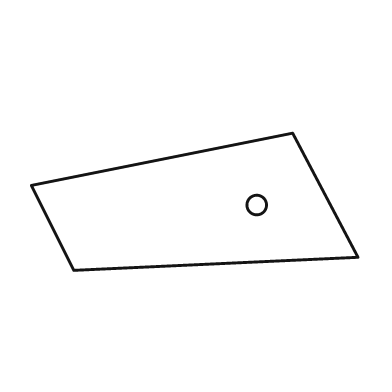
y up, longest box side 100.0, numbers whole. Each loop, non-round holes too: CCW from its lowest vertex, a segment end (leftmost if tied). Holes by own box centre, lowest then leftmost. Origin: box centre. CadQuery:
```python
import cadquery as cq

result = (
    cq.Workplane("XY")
    .moveTo(-37.0, -21.0)
    .lineTo(50.0, -17.0)
    .lineTo(30.0, 21.0)
    .lineTo(-50.0, 5.0)
    .close()
    .moveTo(19.0, -1.0)
    .circle(3.0)
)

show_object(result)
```